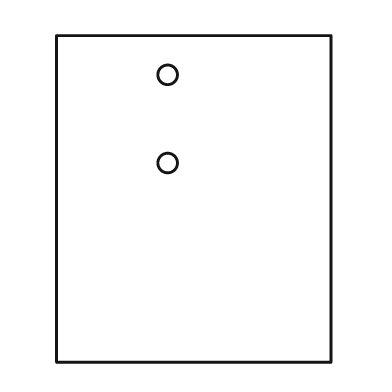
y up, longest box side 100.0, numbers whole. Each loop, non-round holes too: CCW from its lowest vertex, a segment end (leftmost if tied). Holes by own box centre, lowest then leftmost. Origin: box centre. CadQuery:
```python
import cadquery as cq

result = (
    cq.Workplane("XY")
    .moveTo(-42.0, -50.0)
    .lineTo(42.0, -50.0)
    .lineTo(42.0, 50.0)
    .lineTo(-42.0, 50.0)
    .close()
    .moveTo(-8.0, 11.0)
    .circle(3.0)
    .moveTo(-8.0, 38.0)
    .circle(3.0)
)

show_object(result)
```